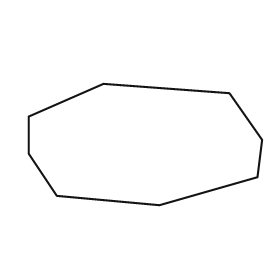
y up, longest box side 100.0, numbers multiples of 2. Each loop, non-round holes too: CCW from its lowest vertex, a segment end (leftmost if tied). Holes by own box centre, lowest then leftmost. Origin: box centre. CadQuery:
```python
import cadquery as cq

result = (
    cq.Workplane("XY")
    .moveTo(6.0, -26.0)
    .lineTo(48.0, -14.0)
    .lineTo(50.0, 2.0)
    .lineTo(36.0, 22.0)
    .lineTo(-18.0, 26.0)
    .lineTo(-50.0, 12.0)
    .lineTo(-50.0, -4.0)
    .lineTo(-38.0, -22.0)
    .close()
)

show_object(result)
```